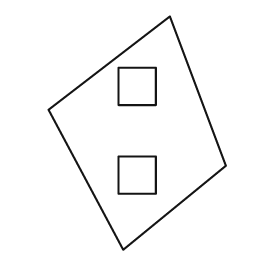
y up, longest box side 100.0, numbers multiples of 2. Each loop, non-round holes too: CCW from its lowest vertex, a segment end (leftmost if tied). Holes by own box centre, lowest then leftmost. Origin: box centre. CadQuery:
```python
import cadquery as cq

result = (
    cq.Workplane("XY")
    .moveTo(-6.0, -50.0)
    .lineTo(38.0, -14.0)
    .lineTo(14.0, 50.0)
    .lineTo(-38.0, 10.0)
    .close()
    .moveTo(-8.0, -26.0)
    .lineTo(8.0, -26.0)
    .lineTo(8.0, -10.0)
    .lineTo(-8.0, -10.0)
    .close()
    .moveTo(-8.0, 12.0)
    .lineTo(8.0, 12.0)
    .lineTo(8.0, 28.0)
    .lineTo(-8.0, 28.0)
    .close()
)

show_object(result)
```